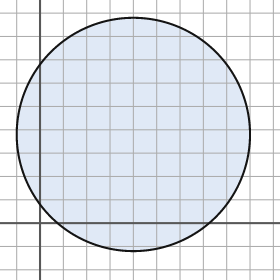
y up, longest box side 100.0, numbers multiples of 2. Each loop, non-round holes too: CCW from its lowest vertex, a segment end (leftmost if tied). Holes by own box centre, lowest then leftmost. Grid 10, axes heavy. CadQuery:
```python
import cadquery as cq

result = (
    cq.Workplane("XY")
    .moveTo(40.0, 38.0)
    .circle(50.0)
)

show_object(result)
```